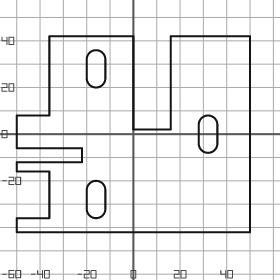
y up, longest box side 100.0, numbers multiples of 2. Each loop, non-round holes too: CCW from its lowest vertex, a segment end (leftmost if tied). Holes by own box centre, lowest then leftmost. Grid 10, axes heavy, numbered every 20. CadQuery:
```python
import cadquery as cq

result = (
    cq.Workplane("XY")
    .moveTo(-50.0, -42.0)
    .lineTo(50.0, -42.0)
    .lineTo(50.0, 42.0)
    .lineTo(16.0, 42.0)
    .lineTo(16.0, 2.0)
    .lineTo(0.0, 2.0)
    .lineTo(0.0, 42.0)
    .lineTo(-36.0, 42.0)
    .lineTo(-36.0, 8.0)
    .lineTo(-50.0, 8.0)
    .lineTo(-50.0, -6.0)
    .lineTo(-22.0, -6.0)
    .lineTo(-22.0, -12.0)
    .lineTo(-50.0, -12.0)
    .lineTo(-50.0, -16.0)
    .lineTo(-36.0, -16.0)
    .lineTo(-36.0, -36.0)
    .lineTo(-50.0, -36.0)
    .close()
    .moveTo(-20.0, -32.0)
    .threePointArc((-16.0, -36.0), (-12.0, -32.0))
    .lineTo(-12.0, -24.0)
    .threePointArc((-16.0, -20.0), (-20.0, -24.0))
    .close()
    .moveTo(28.0, -4.0)
    .threePointArc((32.0, -8.0), (36.0, -4.0))
    .lineTo(36.0, 4.0)
    .threePointArc((32.0, 8.0), (28.0, 4.0))
    .close()
    .moveTo(-20.0, 24.0)
    .threePointArc((-16.0, 20.0), (-12.0, 24.0))
    .lineTo(-12.0, 32.0)
    .threePointArc((-16.0, 36.0), (-20.0, 32.0))
    .close()
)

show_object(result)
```